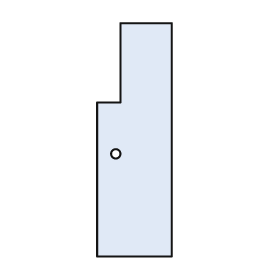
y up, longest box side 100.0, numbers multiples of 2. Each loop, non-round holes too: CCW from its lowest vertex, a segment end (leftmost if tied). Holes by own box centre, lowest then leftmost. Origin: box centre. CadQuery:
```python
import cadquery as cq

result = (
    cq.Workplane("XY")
    .moveTo(-16.0, -50.0)
    .lineTo(16.0, -50.0)
    .lineTo(16.0, 50.0)
    .lineTo(-6.0, 50.0)
    .lineTo(-6.0, 16.0)
    .lineTo(-16.0, 16.0)
    .close()
    .moveTo(-8.0, -6.0)
    .circle(2.0)
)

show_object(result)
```